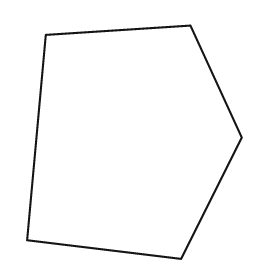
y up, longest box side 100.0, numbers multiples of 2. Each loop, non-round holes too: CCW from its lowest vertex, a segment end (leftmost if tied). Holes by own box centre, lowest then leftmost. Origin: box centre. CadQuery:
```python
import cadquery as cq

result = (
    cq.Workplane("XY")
    .moveTo(20.0, -50.0)
    .lineTo(46.0, 2.0)
    .lineTo(24.0, 50.0)
    .lineTo(-38.0, 46.0)
    .lineTo(-46.0, -42.0)
    .close()
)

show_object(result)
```